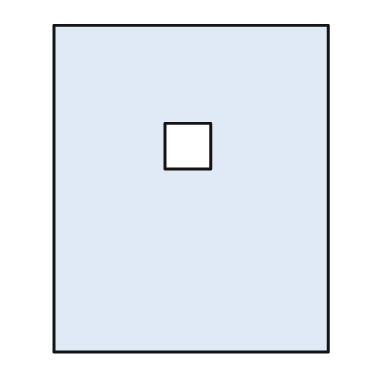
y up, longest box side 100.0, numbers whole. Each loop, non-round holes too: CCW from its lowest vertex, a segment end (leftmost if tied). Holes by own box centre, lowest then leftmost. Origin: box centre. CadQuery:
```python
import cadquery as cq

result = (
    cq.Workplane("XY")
    .moveTo(-42.0, -50.0)
    .lineTo(42.0, -50.0)
    .lineTo(42.0, 50.0)
    .lineTo(-42.0, 50.0)
    .close()
    .moveTo(-8.0, 6.0)
    .lineTo(6.0, 6.0)
    .lineTo(6.0, 20.0)
    .lineTo(-8.0, 20.0)
    .close()
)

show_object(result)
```